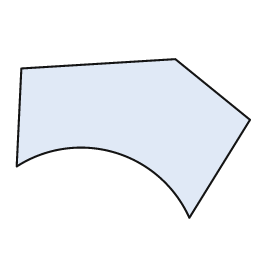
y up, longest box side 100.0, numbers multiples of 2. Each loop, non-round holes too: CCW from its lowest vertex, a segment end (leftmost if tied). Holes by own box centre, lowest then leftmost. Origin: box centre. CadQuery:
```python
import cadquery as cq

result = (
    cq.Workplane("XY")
    .moveTo(24.0, -34.0)
    .lineTo(50.0, 8.0)
    .lineTo(18.0, 34.0)
    .lineTo(-48.0, 30.0)
    .lineTo(-50.0, -12.0)
    .threePointArc((-8.0, -6.0), (24.0, -34.0))
    .close()
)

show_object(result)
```